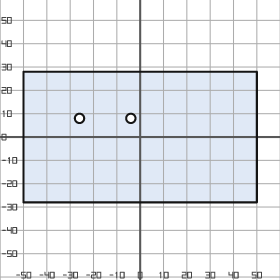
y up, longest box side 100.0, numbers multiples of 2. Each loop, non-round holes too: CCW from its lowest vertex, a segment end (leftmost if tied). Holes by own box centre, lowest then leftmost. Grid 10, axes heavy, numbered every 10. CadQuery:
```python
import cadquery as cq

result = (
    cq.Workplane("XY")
    .moveTo(-50.0, -28.0)
    .lineTo(50.0, -28.0)
    .lineTo(50.0, 28.0)
    .lineTo(-50.0, 28.0)
    .close()
    .moveTo(-26.0, 8.0)
    .circle(2.0)
    .moveTo(-4.0, 8.0)
    .circle(2.0)
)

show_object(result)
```